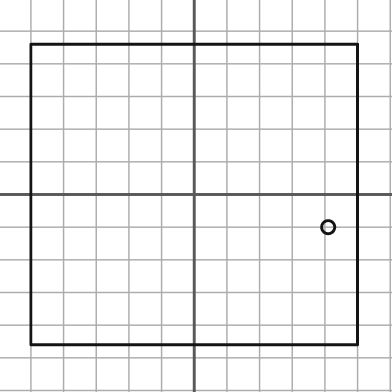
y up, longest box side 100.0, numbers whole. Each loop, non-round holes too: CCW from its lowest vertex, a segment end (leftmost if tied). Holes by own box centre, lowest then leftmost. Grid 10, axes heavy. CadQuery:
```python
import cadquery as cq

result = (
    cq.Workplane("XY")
    .moveTo(-50.0, -46.0)
    .lineTo(50.0, -46.0)
    .lineTo(50.0, 46.0)
    .lineTo(-50.0, 46.0)
    .close()
    .moveTo(41.0, -10.0)
    .circle(2.0)
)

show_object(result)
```